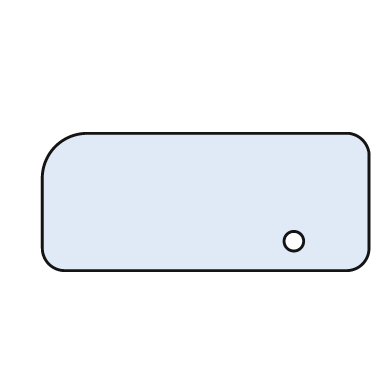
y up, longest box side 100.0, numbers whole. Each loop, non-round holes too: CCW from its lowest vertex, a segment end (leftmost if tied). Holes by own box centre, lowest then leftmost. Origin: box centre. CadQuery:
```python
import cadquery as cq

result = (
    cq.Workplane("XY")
    .moveTo(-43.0, -21.0)
    .lineTo(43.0, -21.0)
    .threePointArc((48.0, -19.0), (50.0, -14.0))
    .lineTo(50.0, 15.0)
    .threePointArc((48.0, 19.0), (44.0, 21.0))
    .lineTo(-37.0, 21.0)
    .threePointArc((-46.0, 17.0), (-50.0, 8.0))
    .lineTo(-50.0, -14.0)
    .threePointArc((-48.0, -19.0), (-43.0, -21.0))
    .close()
    .moveTo(27.0, -12.0)
    .circle(3.0)
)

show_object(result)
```